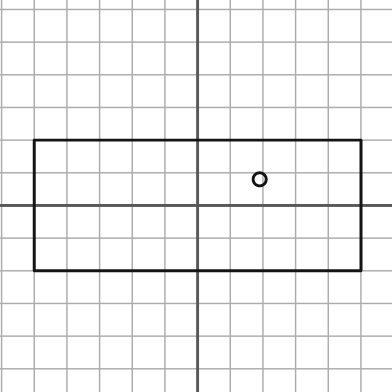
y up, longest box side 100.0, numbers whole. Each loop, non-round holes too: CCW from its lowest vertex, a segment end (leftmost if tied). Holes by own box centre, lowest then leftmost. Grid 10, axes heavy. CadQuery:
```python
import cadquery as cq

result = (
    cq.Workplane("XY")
    .moveTo(-50.0, -20.0)
    .lineTo(50.0, -20.0)
    .lineTo(50.0, 20.0)
    .lineTo(-50.0, 20.0)
    .close()
    .moveTo(19.0, 8.0)
    .circle(2.0)
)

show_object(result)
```